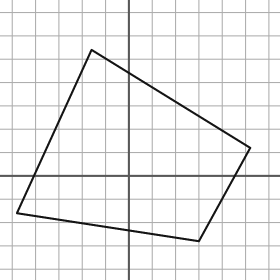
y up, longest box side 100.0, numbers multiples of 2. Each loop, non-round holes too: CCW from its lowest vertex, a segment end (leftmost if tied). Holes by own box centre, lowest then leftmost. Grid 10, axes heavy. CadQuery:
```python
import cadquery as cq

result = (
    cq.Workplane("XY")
    .moveTo(30.0, -28.0)
    .lineTo(52.0, 12.0)
    .lineTo(-16.0, 54.0)
    .lineTo(-48.0, -16.0)
    .close()
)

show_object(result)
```